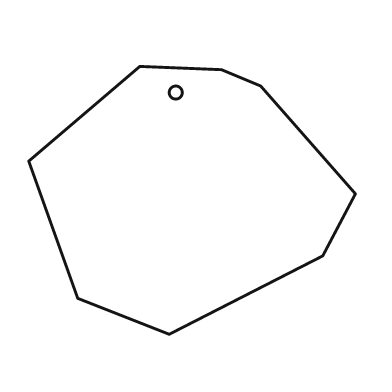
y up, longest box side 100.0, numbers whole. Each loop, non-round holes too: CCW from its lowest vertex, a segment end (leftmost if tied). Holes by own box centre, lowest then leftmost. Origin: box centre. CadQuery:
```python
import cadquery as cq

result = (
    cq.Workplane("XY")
    .moveTo(-7.0, -41.0)
    .lineTo(40.0, -17.0)
    .lineTo(50.0, 2.0)
    .lineTo(21.0, 35.0)
    .lineTo(9.0, 40.0)
    .lineTo(-16.0, 41.0)
    .lineTo(-50.0, 12.0)
    .lineTo(-35.0, -30.0)
    .close()
    .moveTo(-5.0, 33.0)
    .circle(2.0)
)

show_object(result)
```